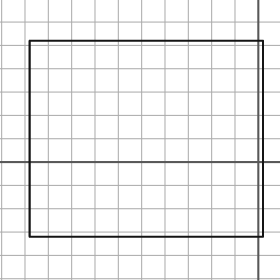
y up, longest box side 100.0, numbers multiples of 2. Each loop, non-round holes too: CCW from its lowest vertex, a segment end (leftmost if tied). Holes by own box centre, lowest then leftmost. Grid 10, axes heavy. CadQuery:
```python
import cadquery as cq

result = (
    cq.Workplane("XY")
    .moveTo(-98.0, -32.0)
    .lineTo(2.0, -32.0)
    .lineTo(2.0, 52.0)
    .lineTo(-98.0, 52.0)
    .close()
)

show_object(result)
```